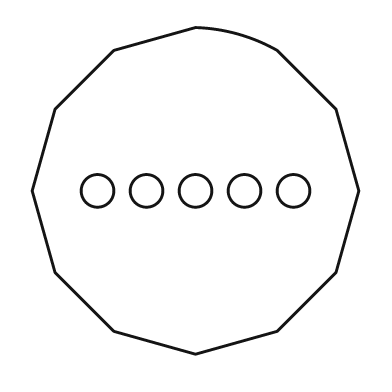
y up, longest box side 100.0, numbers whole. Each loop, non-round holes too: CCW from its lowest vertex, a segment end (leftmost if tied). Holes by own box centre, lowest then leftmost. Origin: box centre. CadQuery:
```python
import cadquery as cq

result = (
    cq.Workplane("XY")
    .moveTo(0.0, -50.0)
    .lineTo(25.0, -43.0)
    .lineTo(43.0, -25.0)
    .lineTo(50.0, 0.0)
    .lineTo(43.0, 25.0)
    .lineTo(25.0, 43.0)
    .threePointArc((13.0, 48.0), (0.0, 50.0))
    .lineTo(-25.0, 43.0)
    .lineTo(-43.0, 25.0)
    .lineTo(-50.0, 0.0)
    .lineTo(-43.0, -25.0)
    .lineTo(-25.0, -43.0)
    .close()
    .moveTo(-30.0, 0.0)
    .circle(5.0)
    .moveTo(-15.0, 0.0)
    .circle(5.0)
    .moveTo(0.0, 0.0)
    .circle(5.0)
    .moveTo(15.0, 0.0)
    .circle(5.0)
    .moveTo(30.0, 0.0)
    .circle(5.0)
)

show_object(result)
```